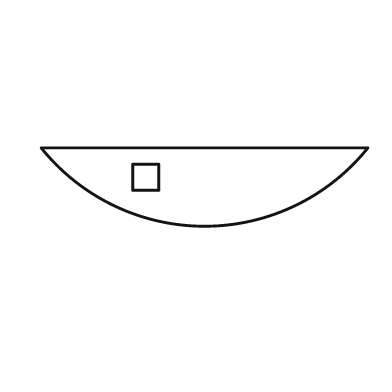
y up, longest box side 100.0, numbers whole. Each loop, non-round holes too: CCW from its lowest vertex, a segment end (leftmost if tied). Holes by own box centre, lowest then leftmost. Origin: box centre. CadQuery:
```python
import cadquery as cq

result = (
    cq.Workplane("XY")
    .moveTo(-50.0, 12.0)
    .threePointArc((0.0, -12.0), (50.0, 12.0))
    .close()
    .moveTo(-22.0, -1.0)
    .lineTo(-14.0, -1.0)
    .lineTo(-14.0, 7.0)
    .lineTo(-22.0, 7.0)
    .close()
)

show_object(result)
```